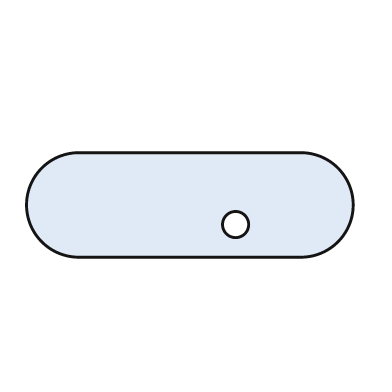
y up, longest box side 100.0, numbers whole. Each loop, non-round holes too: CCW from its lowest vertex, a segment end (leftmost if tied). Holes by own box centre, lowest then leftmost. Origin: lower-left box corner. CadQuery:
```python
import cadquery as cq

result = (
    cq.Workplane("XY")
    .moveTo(16.0, 0.0)
    .lineTo(84.0, 0.0)
    .threePointArc((100.0, 16.0), (84.0, 32.0))
    .lineTo(16.0, 32.0)
    .threePointArc((0.0, 16.0), (16.0, 0.0))
    .close()
    .moveTo(64.0, 10.0)
    .circle(4.0)
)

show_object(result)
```